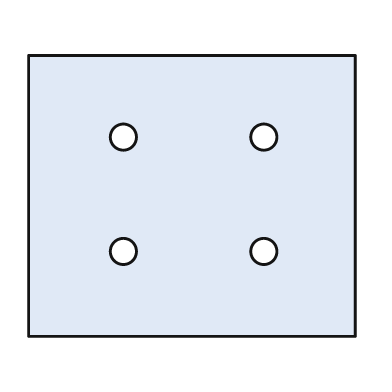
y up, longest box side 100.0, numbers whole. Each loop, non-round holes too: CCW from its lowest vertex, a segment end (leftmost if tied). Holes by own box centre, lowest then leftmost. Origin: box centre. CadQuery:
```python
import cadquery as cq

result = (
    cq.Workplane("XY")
    .moveTo(-50.0, -43.0)
    .lineTo(50.0, -43.0)
    .lineTo(50.0, 43.0)
    .lineTo(-50.0, 43.0)
    .close()
    .moveTo(-21.0, -17.0)
    .circle(4.0)
    .moveTo(22.0, -17.0)
    .circle(4.0)
    .moveTo(-21.0, 18.0)
    .circle(4.0)
    .moveTo(22.0, 18.0)
    .circle(4.0)
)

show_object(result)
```